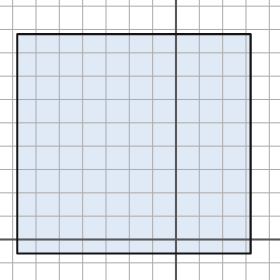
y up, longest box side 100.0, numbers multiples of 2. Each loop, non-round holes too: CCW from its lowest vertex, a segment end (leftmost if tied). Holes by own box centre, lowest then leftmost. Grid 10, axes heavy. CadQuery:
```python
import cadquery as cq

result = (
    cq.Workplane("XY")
    .moveTo(-68.0, -6.0)
    .lineTo(32.0, -6.0)
    .lineTo(32.0, 88.0)
    .lineTo(-68.0, 88.0)
    .close()
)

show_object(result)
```